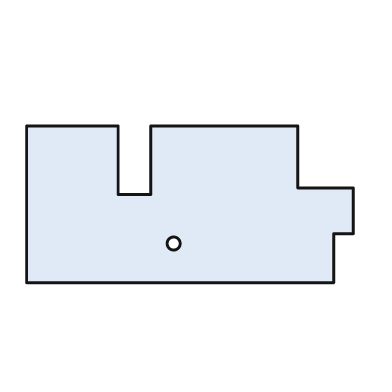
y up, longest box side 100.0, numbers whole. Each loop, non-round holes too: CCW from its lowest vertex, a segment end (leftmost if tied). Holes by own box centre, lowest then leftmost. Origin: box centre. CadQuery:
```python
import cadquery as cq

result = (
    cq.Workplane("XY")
    .moveTo(-50.0, -24.0)
    .lineTo(44.0, -24.0)
    .lineTo(44.0, -9.0)
    .lineTo(50.0, -9.0)
    .lineTo(50.0, 5.0)
    .lineTo(33.0, 5.0)
    .lineTo(33.0, 24.0)
    .lineTo(-12.0, 24.0)
    .lineTo(-12.0, 3.0)
    .lineTo(-22.0, 3.0)
    .lineTo(-22.0, 24.0)
    .lineTo(-50.0, 24.0)
    .close()
    .moveTo(-5.0, -12.0)
    .circle(2.0)
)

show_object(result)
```